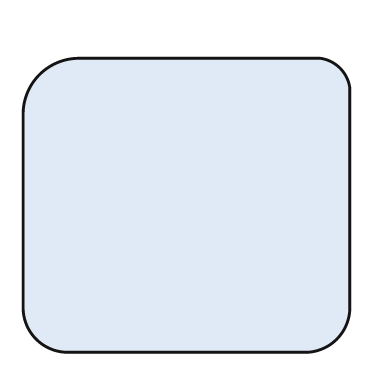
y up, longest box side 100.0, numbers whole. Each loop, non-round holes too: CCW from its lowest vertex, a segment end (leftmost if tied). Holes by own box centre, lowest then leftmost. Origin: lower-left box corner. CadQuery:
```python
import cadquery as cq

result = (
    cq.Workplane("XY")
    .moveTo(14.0, 0.0)
    .lineTo(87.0, 0.0)
    .threePointArc((96.0, 4.0), (100.0, 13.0))
    .lineTo(100.0, 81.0)
    .threePointArc((97.0, 87.0), (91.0, 90.0))
    .lineTo(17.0, 90.0)
    .threePointArc((5.0, 85.0), (0.0, 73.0))
    .lineTo(0.0, 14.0)
    .threePointArc((4.0, 4.0), (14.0, 0.0))
    .close()
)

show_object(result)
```